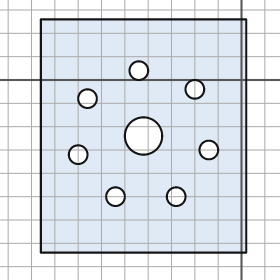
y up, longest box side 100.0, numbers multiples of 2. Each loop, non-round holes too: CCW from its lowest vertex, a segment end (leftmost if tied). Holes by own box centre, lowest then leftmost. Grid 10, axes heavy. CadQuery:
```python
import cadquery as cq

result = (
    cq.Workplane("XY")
    .moveTo(-86.0, -74.0)
    .lineTo(2.0, -74.0)
    .lineTo(2.0, 26.0)
    .lineTo(-86.0, 26.0)
    .close()
    .moveTo(-54.0, -50.0)
    .circle(4.0)
    .moveTo(-28.0, -50.0)
    .circle(4.0)
    .moveTo(-70.0, -32.0)
    .circle(4.0)
    .moveTo(-14.0, -30.0)
    .circle(4.0)
    .moveTo(-42.0, -24.0)
    .circle(8.0)
    .moveTo(-66.0, -8.0)
    .circle(4.0)
    .moveTo(-20.0, -4.0)
    .circle(4.0)
    .moveTo(-44.0, 4.0)
    .circle(4.0)
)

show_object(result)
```